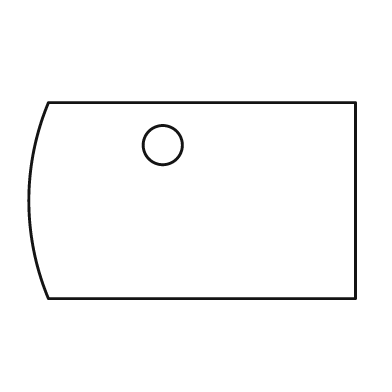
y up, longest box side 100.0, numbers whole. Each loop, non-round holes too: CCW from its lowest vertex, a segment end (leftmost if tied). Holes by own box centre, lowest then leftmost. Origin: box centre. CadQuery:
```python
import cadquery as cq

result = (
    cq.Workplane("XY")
    .moveTo(-44.0, -30.0)
    .lineTo(50.0, -30.0)
    .lineTo(50.0, 30.0)
    .lineTo(-44.0, 30.0)
    .threePointArc((-50.0, 0.0), (-44.0, -30.0))
    .close()
    .moveTo(-9.0, 17.0)
    .circle(6.0)
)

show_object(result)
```